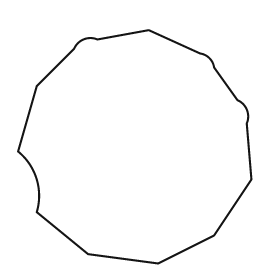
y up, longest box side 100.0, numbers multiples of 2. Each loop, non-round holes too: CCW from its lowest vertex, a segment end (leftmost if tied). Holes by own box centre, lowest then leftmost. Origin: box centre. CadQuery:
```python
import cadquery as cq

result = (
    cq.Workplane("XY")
    .moveTo(10.0, -50.0)
    .lineTo(34.0, -38.0)
    .lineTo(50.0, -14.0)
    .lineTo(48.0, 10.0)
    .threePointArc((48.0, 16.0), (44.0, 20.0))
    .lineTo(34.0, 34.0)
    .threePointArc((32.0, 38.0), (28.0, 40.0))
    .lineTo(6.0, 50.0)
    .lineTo(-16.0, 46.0)
    .threePointArc((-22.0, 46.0), (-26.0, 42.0))
    .lineTo(-42.0, 26.0)
    .lineTo(-50.0, -2.0)
    .threePointArc((-42.0, -14.0), (-42.0, -28.0))
    .lineTo(-20.0, -46.0)
    .close()
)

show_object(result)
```